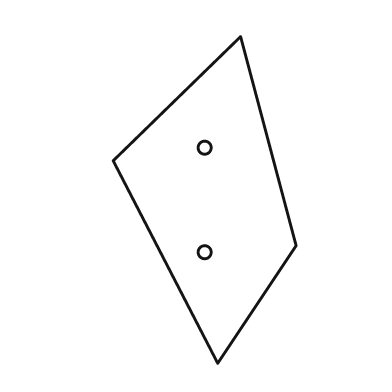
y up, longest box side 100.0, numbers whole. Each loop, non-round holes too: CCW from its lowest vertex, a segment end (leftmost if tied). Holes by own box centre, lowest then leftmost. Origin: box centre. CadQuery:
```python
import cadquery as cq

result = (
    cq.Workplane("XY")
    .moveTo(4.0, -50.0)
    .lineTo(28.0, -14.0)
    .lineTo(11.0, 50.0)
    .lineTo(-28.0, 12.0)
    .close()
    .moveTo(0.0, -16.0)
    .circle(2.0)
    .moveTo(0.0, 16.0)
    .circle(2.0)
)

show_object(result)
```